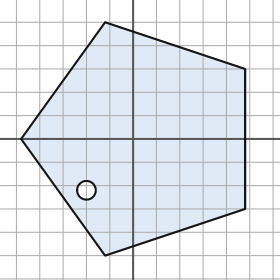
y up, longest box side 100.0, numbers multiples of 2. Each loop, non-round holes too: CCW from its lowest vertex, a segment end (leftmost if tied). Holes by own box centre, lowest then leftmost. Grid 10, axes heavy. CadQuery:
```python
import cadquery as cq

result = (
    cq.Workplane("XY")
    .moveTo(-12.0, -50.0)
    .lineTo(48.0, -30.0)
    .lineTo(48.0, 30.0)
    .lineTo(-12.0, 50.0)
    .lineTo(-48.0, 0.0)
    .close()
    .moveTo(-20.0, -22.0)
    .circle(4.0)
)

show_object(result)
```